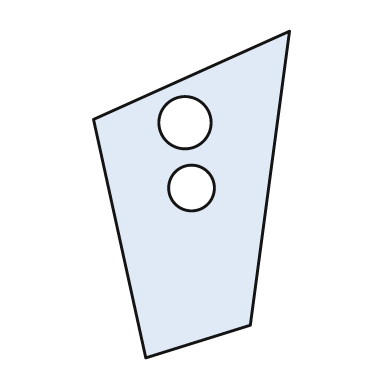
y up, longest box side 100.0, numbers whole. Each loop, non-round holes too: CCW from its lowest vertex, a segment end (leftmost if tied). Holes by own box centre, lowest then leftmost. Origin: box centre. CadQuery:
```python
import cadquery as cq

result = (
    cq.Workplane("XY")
    .moveTo(-14.0, -50.0)
    .lineTo(18.0, -40.0)
    .lineTo(30.0, 50.0)
    .lineTo(-30.0, 23.0)
    .close()
    .moveTo(0.0, 2.0)
    .circle(7.0)
    .moveTo(-2.0, 22.0)
    .circle(8.0)
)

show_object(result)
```